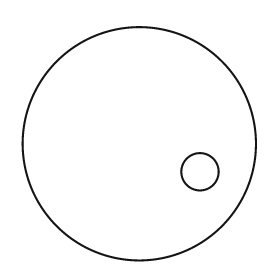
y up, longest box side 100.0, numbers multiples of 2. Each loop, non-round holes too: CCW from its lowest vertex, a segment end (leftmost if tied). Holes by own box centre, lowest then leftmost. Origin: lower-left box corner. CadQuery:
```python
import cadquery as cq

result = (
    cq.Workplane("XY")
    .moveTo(50.0, 50.0)
    .circle(50.0)
    .moveTo(76.0, 38.0)
    .circle(8.0)
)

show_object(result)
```